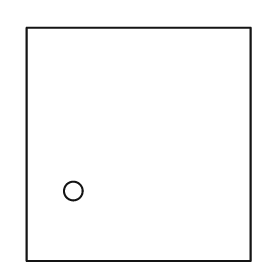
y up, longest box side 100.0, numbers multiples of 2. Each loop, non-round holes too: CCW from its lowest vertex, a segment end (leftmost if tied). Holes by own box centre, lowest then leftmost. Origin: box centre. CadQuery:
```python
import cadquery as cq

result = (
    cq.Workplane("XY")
    .moveTo(-48.0, -50.0)
    .lineTo(48.0, -50.0)
    .lineTo(48.0, 50.0)
    .lineTo(-48.0, 50.0)
    .close()
    .moveTo(-28.0, -20.0)
    .circle(4.0)
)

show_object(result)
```